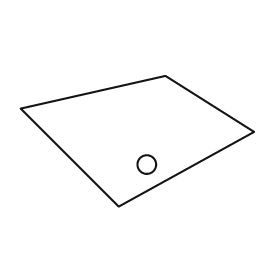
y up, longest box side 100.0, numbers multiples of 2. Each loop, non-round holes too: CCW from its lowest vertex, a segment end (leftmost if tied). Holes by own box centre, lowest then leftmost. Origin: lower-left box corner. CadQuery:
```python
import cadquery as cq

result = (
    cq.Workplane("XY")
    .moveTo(42.0, 0.0)
    .lineTo(100.0, 32.0)
    .lineTo(62.0, 56.0)
    .lineTo(0.0, 42.0)
    .close()
    .moveTo(54.0, 18.0)
    .circle(4.0)
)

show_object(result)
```